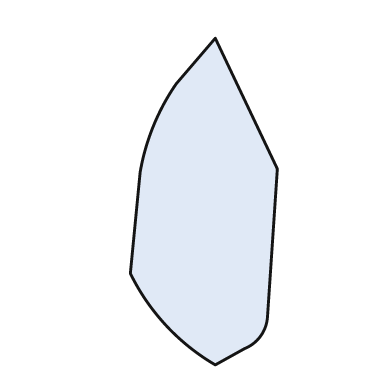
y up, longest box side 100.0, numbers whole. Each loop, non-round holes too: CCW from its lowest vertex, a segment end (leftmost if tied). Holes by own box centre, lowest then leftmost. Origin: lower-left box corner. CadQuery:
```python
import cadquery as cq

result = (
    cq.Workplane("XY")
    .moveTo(26.0, 0.0)
    .lineTo(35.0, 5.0)
    .threePointArc((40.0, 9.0), (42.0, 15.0))
    .lineTo(45.0, 60.0)
    .lineTo(26.0, 100.0)
    .lineTo(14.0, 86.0)
    .threePointArc((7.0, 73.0), (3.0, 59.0))
    .lineTo(0.0, 28.0)
    .threePointArc((11.0, 12.0), (26.0, 0.0))
    .close()
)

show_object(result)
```